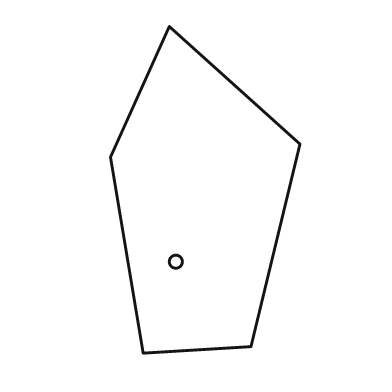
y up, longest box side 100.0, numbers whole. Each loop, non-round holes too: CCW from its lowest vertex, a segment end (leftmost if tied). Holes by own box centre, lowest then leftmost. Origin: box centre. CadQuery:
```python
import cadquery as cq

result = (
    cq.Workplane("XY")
    .moveTo(-19.0, -50.0)
    .lineTo(14.0, -48.0)
    .lineTo(29.0, 14.0)
    .lineTo(-11.0, 50.0)
    .lineTo(-29.0, 10.0)
    .close()
    .moveTo(-9.0, -22.0)
    .circle(2.0)
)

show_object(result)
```